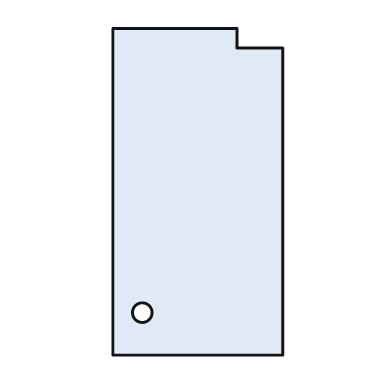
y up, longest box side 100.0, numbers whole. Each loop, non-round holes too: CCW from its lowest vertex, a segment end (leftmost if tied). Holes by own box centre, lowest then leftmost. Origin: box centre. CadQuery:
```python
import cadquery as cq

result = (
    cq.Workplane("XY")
    .moveTo(-26.0, -50.0)
    .lineTo(26.0, -50.0)
    .lineTo(26.0, 44.0)
    .lineTo(12.0, 44.0)
    .lineTo(12.0, 50.0)
    .lineTo(-26.0, 50.0)
    .close()
    .moveTo(-17.0, -37.0)
    .circle(3.0)
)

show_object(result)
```